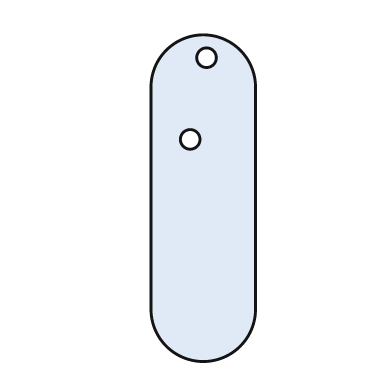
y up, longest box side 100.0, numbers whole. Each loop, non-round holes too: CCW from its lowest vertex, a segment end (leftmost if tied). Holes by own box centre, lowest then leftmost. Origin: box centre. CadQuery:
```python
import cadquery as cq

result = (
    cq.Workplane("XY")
    .moveTo(-16.0, -34.0)
    .threePointArc((0.0, -50.0), (16.0, -34.0))
    .lineTo(16.0, 34.0)
    .threePointArc((0.0, 50.0), (-16.0, 34.0))
    .close()
    .moveTo(-4.0, 18.0)
    .circle(3.0)
    .moveTo(1.0, 43.0)
    .circle(3.0)
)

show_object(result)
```